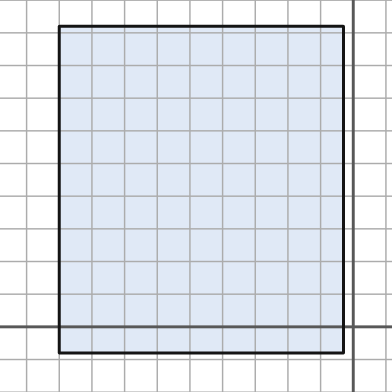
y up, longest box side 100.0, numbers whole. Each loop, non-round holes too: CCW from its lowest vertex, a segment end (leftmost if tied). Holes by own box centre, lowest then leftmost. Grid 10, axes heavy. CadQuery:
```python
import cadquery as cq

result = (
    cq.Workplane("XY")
    .moveTo(-90.0, -8.0)
    .lineTo(-3.0, -8.0)
    .lineTo(-3.0, 92.0)
    .lineTo(-90.0, 92.0)
    .close()
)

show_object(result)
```